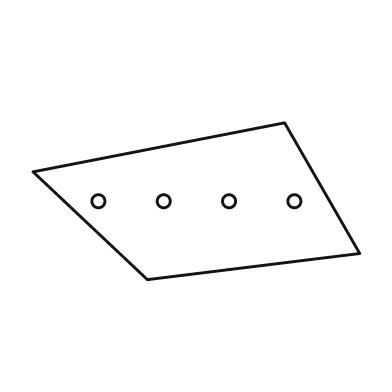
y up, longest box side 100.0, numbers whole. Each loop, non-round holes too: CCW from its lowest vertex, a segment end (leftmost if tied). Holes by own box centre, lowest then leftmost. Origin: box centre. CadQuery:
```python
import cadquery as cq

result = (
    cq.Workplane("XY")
    .moveTo(-15.0, -24.0)
    .lineTo(50.0, -16.0)
    .lineTo(27.0, 24.0)
    .lineTo(-50.0, 9.0)
    .close()
    .moveTo(-30.0, 0.0)
    .circle(2.0)
    .moveTo(-10.0, 0.0)
    .circle(2.0)
    .moveTo(10.0, 0.0)
    .circle(2.0)
    .moveTo(30.0, 0.0)
    .circle(2.0)
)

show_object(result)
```